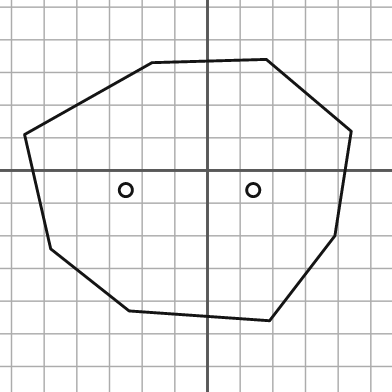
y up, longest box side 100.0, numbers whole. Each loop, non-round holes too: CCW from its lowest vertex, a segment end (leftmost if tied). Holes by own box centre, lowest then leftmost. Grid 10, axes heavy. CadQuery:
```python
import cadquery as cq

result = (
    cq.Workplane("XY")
    .moveTo(19.0, -46.0)
    .lineTo(39.0, -20.0)
    .lineTo(44.0, 12.0)
    .lineTo(18.0, 34.0)
    .lineTo(-17.0, 33.0)
    .lineTo(-56.0, 11.0)
    .lineTo(-48.0, -24.0)
    .lineTo(-24.0, -43.0)
    .close()
    .moveTo(-25.0, -6.0)
    .circle(2.0)
    .moveTo(14.0, -6.0)
    .circle(2.0)
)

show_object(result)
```